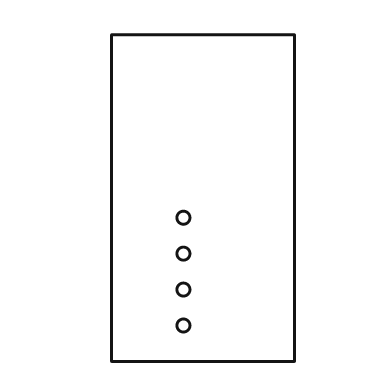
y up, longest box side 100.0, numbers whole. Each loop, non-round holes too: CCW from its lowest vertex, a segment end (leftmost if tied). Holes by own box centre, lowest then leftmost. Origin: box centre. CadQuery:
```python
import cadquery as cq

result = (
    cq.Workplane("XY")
    .moveTo(-28.0, -50.0)
    .lineTo(28.0, -50.0)
    .lineTo(28.0, 50.0)
    .lineTo(-28.0, 50.0)
    .close()
    .moveTo(-6.0, -39.0)
    .circle(2.0)
    .moveTo(-6.0, -28.0)
    .circle(2.0)
    .moveTo(-6.0, -17.0)
    .circle(2.0)
    .moveTo(-6.0, -6.0)
    .circle(2.0)
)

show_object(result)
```